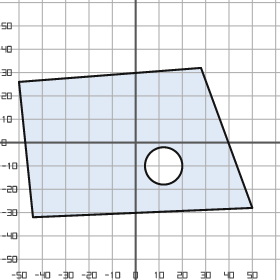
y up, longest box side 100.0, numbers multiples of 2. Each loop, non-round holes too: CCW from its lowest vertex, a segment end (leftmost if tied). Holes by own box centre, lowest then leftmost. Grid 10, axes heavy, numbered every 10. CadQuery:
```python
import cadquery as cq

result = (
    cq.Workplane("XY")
    .moveTo(-44.0, -32.0)
    .lineTo(50.0, -28.0)
    .lineTo(28.0, 32.0)
    .lineTo(-50.0, 26.0)
    .close()
    .moveTo(12.0, -10.0)
    .circle(8.0)
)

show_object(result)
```